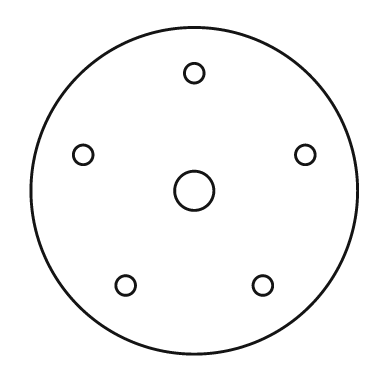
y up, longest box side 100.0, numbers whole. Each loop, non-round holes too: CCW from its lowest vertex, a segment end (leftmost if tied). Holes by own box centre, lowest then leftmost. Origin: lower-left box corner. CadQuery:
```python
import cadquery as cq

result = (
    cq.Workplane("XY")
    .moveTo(50.0, 50.0)
    .circle(50.0)
    .moveTo(29.0, 21.0)
    .circle(3.0)
    .moveTo(71.0, 21.0)
    .circle(3.0)
    .moveTo(50.0, 50.0)
    .circle(6.0)
    .moveTo(16.0, 61.0)
    .circle(3.0)
    .moveTo(84.0, 61.0)
    .circle(3.0)
    .moveTo(50.0, 86.0)
    .circle(3.0)
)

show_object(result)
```